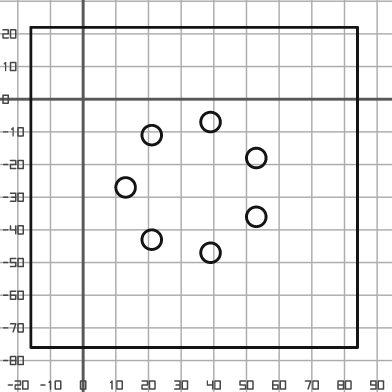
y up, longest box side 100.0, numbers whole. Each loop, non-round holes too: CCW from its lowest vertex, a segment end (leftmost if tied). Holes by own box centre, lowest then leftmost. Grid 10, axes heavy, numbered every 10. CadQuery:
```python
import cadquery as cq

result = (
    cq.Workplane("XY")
    .moveTo(-16.0, -76.0)
    .lineTo(84.0, -76.0)
    .lineTo(84.0, 22.0)
    .lineTo(-16.0, 22.0)
    .close()
    .moveTo(39.0, -47.0)
    .circle(3.0)
    .moveTo(21.0, -43.0)
    .circle(3.0)
    .moveTo(53.0, -36.0)
    .circle(3.0)
    .moveTo(13.0, -27.0)
    .circle(3.0)
    .moveTo(53.0, -18.0)
    .circle(3.0)
    .moveTo(21.0, -11.0)
    .circle(3.0)
    .moveTo(39.0, -7.0)
    .circle(3.0)
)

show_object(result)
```